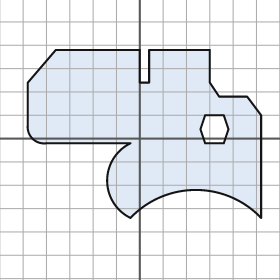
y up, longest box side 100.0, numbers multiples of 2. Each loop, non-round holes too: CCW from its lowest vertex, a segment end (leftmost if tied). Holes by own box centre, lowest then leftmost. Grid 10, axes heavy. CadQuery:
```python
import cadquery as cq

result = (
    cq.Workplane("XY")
    .moveTo(-4.0, -34.0)
    .threePointArc((24.0, -22.0), (52.0, -34.0))
    .lineTo(52.0, 10.0)
    .lineTo(46.0, 18.0)
    .lineTo(34.0, 18.0)
    .lineTo(30.0, 24.0)
    .lineTo(30.0, 38.0)
    .lineTo(4.0, 38.0)
    .lineTo(4.0, 24.0)
    .lineTo(0.0, 24.0)
    .lineTo(0.0, 38.0)
    .lineTo(-36.0, 38.0)
    .lineTo(-48.0, 24.0)
    .lineTo(-48.0, 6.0)
    .threePointArc((-46.0, 0.0), (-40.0, -2.0))
    .lineTo(-4.0, -2.0)
    .threePointArc((-14.0, -18.0), (-4.0, -34.0))
    .close()
    .moveTo(28.0, -2.0)
    .lineTo(36.0, -2.0)
    .lineTo(38.0, 4.0)
    .lineTo(36.0, 10.0)
    .lineTo(28.0, 10.0)
    .lineTo(26.0, 4.0)
    .close()
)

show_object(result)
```